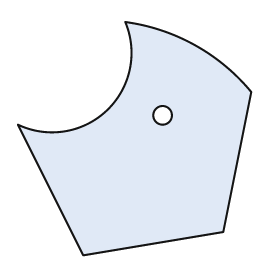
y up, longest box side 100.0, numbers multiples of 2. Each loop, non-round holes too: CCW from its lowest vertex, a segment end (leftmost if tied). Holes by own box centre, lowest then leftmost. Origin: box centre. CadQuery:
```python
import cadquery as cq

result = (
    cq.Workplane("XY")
    .moveTo(-22.0, -50.0)
    .lineTo(38.0, -40.0)
    .lineTo(50.0, 20.0)
    .threePointArc((26.0, 40.0), (-4.0, 50.0))
    .threePointArc((-12.0, 12.0), (-50.0, 6.0))
    .close()
    .moveTo(12.0, 10.0)
    .circle(4.0)
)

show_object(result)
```